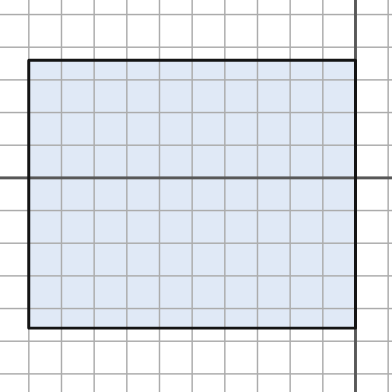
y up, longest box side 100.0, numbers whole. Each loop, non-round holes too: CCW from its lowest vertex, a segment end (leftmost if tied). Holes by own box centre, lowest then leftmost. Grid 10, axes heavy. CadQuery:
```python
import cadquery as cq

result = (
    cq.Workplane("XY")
    .moveTo(-100.0, -46.0)
    .lineTo(0.0, -46.0)
    .lineTo(0.0, 36.0)
    .lineTo(-100.0, 36.0)
    .close()
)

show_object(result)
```